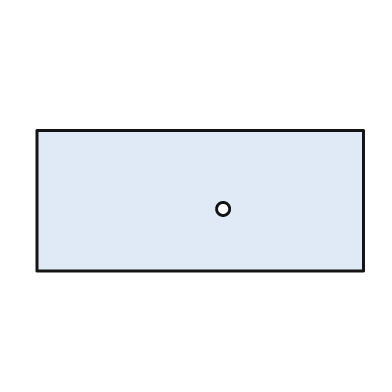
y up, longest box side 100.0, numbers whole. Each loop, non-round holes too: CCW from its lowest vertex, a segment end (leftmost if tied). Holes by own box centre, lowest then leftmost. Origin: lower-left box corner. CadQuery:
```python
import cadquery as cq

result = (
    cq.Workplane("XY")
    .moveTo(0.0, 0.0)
    .lineTo(100.0, 0.0)
    .lineTo(100.0, 43.0)
    .lineTo(0.0, 43.0)
    .close()
    .moveTo(57.0, 19.0)
    .circle(2.0)
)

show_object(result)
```